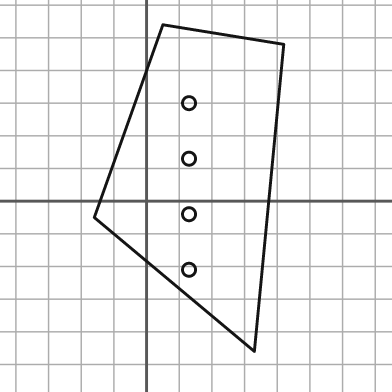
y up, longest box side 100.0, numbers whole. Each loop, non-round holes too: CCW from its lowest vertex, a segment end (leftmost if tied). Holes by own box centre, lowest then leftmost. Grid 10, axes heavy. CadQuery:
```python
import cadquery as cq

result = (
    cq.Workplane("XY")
    .moveTo(33.0, -46.0)
    .lineTo(42.0, 48.0)
    .lineTo(5.0, 54.0)
    .lineTo(-16.0, -5.0)
    .close()
    .moveTo(13.0, -21.0)
    .circle(2.0)
    .moveTo(13.0, -4.0)
    .circle(2.0)
    .moveTo(13.0, 13.0)
    .circle(2.0)
    .moveTo(13.0, 30.0)
    .circle(2.0)
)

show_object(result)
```